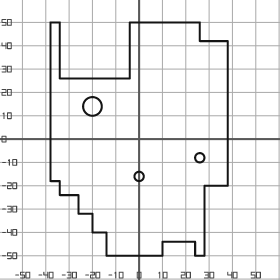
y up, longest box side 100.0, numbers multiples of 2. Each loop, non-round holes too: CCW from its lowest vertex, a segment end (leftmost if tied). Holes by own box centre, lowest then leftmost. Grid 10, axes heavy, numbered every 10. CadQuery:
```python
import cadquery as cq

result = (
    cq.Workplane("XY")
    .moveTo(-14.0, -50.0)
    .lineTo(10.0, -50.0)
    .lineTo(10.0, -44.0)
    .lineTo(24.0, -44.0)
    .lineTo(24.0, -50.0)
    .lineTo(28.0, -50.0)
    .lineTo(28.0, -20.0)
    .lineTo(38.0, -20.0)
    .lineTo(38.0, 42.0)
    .lineTo(26.0, 42.0)
    .lineTo(26.0, 50.0)
    .lineTo(-4.0, 50.0)
    .lineTo(-4.0, 26.0)
    .lineTo(-34.0, 26.0)
    .lineTo(-34.0, 50.0)
    .lineTo(-38.0, 50.0)
    .lineTo(-38.0, -18.0)
    .lineTo(-34.0, -18.0)
    .lineTo(-34.0, -24.0)
    .lineTo(-26.0, -24.0)
    .lineTo(-26.0, -32.0)
    .lineTo(-20.0, -32.0)
    .lineTo(-20.0, -40.0)
    .lineTo(-14.0, -40.0)
    .close()
    .moveTo(0.0, -16.0)
    .circle(2.0)
    .moveTo(26.0, -8.0)
    .circle(2.0)
    .moveTo(-20.0, 14.0)
    .circle(4.0)
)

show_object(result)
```